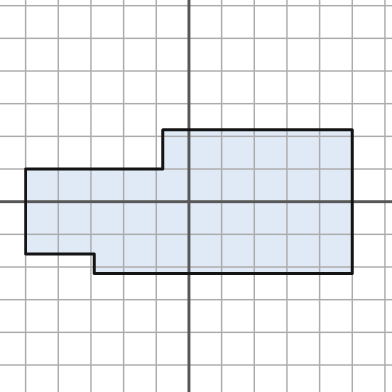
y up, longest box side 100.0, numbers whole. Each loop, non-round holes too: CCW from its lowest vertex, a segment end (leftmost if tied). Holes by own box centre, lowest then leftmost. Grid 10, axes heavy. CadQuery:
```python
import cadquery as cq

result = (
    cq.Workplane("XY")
    .moveTo(-29.0, -22.0)
    .lineTo(50.0, -22.0)
    .lineTo(50.0, 22.0)
    .lineTo(-8.0, 22.0)
    .lineTo(-8.0, 10.0)
    .lineTo(-50.0, 10.0)
    .lineTo(-50.0, -16.0)
    .lineTo(-29.0, -16.0)
    .close()
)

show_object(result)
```